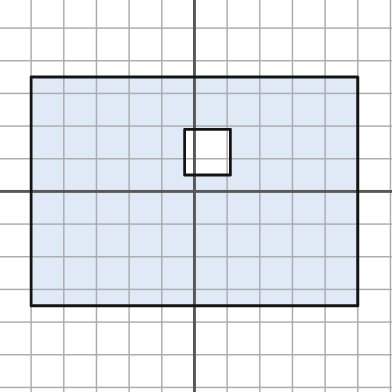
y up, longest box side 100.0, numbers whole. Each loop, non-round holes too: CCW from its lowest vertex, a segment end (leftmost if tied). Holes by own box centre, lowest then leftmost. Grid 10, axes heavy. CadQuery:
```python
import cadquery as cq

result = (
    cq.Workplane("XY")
    .moveTo(-50.0, -35.0)
    .lineTo(50.0, -35.0)
    .lineTo(50.0, 35.0)
    .lineTo(-50.0, 35.0)
    .close()
    .moveTo(-3.0, 5.0)
    .lineTo(11.0, 5.0)
    .lineTo(11.0, 19.0)
    .lineTo(-3.0, 19.0)
    .close()
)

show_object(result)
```